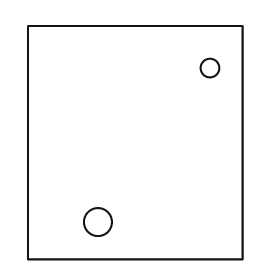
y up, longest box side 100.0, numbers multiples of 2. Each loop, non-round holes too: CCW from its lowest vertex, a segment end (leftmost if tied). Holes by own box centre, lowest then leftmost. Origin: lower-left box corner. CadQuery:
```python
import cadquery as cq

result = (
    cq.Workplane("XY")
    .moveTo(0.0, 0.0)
    .lineTo(92.0, 0.0)
    .lineTo(92.0, 100.0)
    .lineTo(0.0, 100.0)
    .close()
    .moveTo(30.0, 16.0)
    .circle(6.0)
    .moveTo(78.0, 82.0)
    .circle(4.0)
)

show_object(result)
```